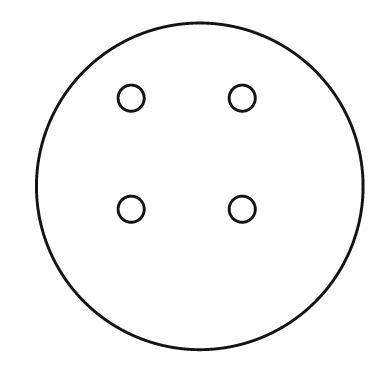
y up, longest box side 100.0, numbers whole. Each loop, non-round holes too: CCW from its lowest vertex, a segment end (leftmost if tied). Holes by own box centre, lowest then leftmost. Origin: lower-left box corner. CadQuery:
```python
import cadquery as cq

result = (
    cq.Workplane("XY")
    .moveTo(50.0, 50.0)
    .circle(50.0)
    .moveTo(29.0, 43.0)
    .circle(4.0)
    .moveTo(63.0, 43.0)
    .circle(4.0)
    .moveTo(29.0, 77.0)
    .circle(4.0)
    .moveTo(63.0, 77.0)
    .circle(4.0)
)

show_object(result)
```